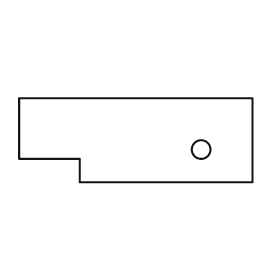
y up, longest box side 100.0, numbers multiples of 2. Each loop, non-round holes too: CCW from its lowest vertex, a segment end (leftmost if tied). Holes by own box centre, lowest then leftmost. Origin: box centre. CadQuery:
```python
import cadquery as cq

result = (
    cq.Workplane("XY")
    .moveTo(-24.0, -18.0)
    .lineTo(50.0, -18.0)
    .lineTo(50.0, 18.0)
    .lineTo(-50.0, 18.0)
    .lineTo(-50.0, -8.0)
    .lineTo(-24.0, -8.0)
    .close()
    .moveTo(28.0, -4.0)
    .circle(4.0)
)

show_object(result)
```